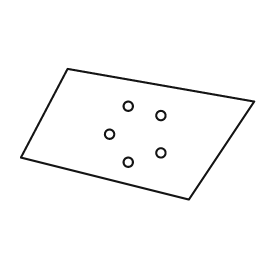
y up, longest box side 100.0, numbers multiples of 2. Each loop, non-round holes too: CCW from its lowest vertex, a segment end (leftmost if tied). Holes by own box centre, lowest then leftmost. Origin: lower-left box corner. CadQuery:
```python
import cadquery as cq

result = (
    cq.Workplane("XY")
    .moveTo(72.0, 0.0)
    .lineTo(100.0, 42.0)
    .lineTo(20.0, 56.0)
    .lineTo(0.0, 18.0)
    .close()
    .moveTo(46.0, 16.0)
    .circle(2.0)
    .moveTo(60.0, 20.0)
    .circle(2.0)
    .moveTo(38.0, 28.0)
    .circle(2.0)
    .moveTo(60.0, 36.0)
    .circle(2.0)
    .moveTo(46.0, 40.0)
    .circle(2.0)
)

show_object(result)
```